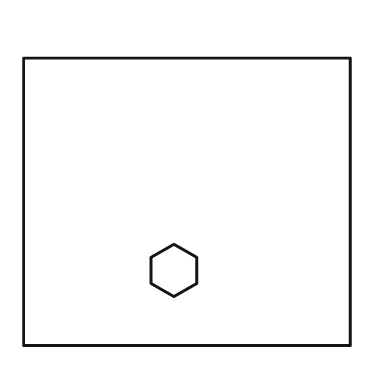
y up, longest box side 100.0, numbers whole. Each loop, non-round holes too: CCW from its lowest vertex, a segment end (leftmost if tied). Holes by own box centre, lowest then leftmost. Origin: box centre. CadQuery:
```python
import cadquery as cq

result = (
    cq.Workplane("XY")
    .moveTo(-50.0, -44.0)
    .lineTo(50.0, -44.0)
    .lineTo(50.0, 44.0)
    .lineTo(-50.0, 44.0)
    .close()
    .moveTo(-4.0, -29.0)
    .lineTo(3.0, -25.0)
    .lineTo(3.0, -17.0)
    .lineTo(-4.0, -13.0)
    .lineTo(-11.0, -17.0)
    .lineTo(-11.0, -25.0)
    .close()
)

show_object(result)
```